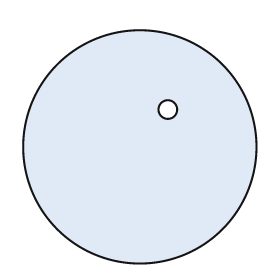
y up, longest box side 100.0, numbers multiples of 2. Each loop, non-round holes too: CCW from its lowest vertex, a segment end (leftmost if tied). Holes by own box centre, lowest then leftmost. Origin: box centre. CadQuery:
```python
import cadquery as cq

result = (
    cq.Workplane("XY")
    .moveTo(0.0, 0.0)
    .circle(50.0)
    .moveTo(12.0, 16.0)
    .circle(4.0)
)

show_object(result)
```